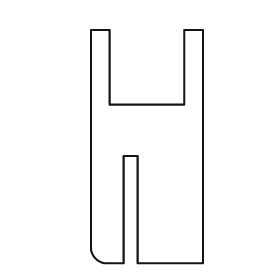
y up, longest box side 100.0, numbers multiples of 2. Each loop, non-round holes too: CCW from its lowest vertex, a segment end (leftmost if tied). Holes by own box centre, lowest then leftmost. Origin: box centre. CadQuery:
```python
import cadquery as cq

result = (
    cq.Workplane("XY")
    .moveTo(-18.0, -50.0)
    .lineTo(-10.0, -50.0)
    .lineTo(-10.0, -4.0)
    .lineTo(-4.0, -4.0)
    .lineTo(-4.0, -50.0)
    .lineTo(24.0, -50.0)
    .lineTo(24.0, 50.0)
    .lineTo(16.0, 50.0)
    .lineTo(16.0, 18.0)
    .lineTo(-16.0, 18.0)
    .lineTo(-16.0, 50.0)
    .lineTo(-24.0, 50.0)
    .lineTo(-24.0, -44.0)
    .threePointArc((-22.0, -48.0), (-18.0, -50.0))
    .close()
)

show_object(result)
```